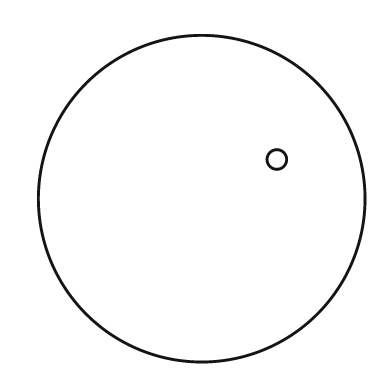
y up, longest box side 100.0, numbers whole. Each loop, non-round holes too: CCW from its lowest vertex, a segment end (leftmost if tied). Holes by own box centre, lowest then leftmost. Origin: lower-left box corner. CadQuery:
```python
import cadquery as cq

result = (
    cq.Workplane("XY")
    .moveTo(50.0, 50.0)
    .circle(50.0)
    .moveTo(73.0, 62.0)
    .circle(3.0)
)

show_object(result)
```